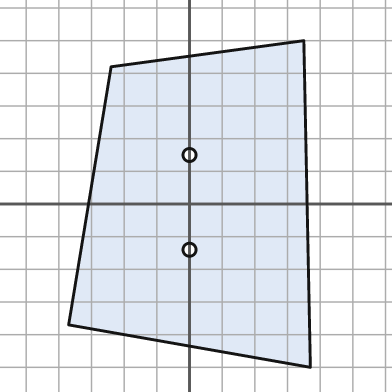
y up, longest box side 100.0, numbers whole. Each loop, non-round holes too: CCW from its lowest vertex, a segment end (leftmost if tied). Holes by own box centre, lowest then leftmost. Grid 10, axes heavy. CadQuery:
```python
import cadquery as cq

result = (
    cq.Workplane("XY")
    .moveTo(37.0, -50.0)
    .lineTo(35.0, 50.0)
    .lineTo(-24.0, 42.0)
    .lineTo(-37.0, -37.0)
    .close()
    .moveTo(0.0, -14.0)
    .circle(2.0)
    .moveTo(0.0, 15.0)
    .circle(2.0)
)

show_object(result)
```